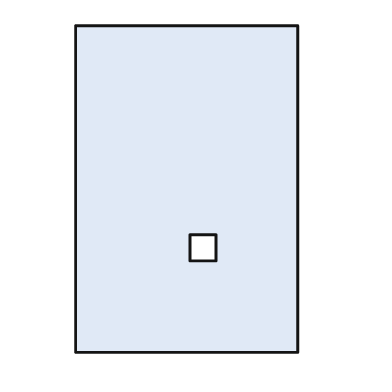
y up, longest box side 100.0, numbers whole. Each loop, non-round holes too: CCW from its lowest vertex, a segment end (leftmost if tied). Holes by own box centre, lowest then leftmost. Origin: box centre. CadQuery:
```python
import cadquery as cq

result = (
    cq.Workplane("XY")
    .moveTo(-34.0, -50.0)
    .lineTo(34.0, -50.0)
    .lineTo(34.0, 50.0)
    .lineTo(-34.0, 50.0)
    .close()
    .moveTo(1.0, -22.0)
    .lineTo(9.0, -22.0)
    .lineTo(9.0, -14.0)
    .lineTo(1.0, -14.0)
    .close()
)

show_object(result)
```